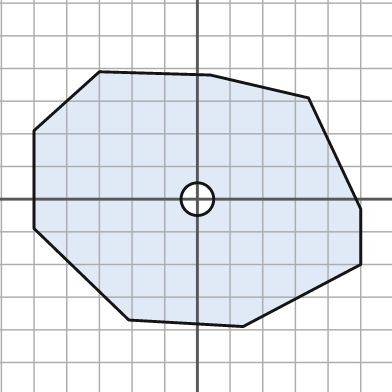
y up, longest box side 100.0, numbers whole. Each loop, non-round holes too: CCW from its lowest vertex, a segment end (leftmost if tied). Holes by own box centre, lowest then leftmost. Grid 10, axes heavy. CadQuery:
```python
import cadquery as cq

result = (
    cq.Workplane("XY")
    .moveTo(14.0, -39.0)
    .lineTo(50.0, -20.0)
    .lineTo(50.0, -3.0)
    .lineTo(34.0, 31.0)
    .lineTo(4.0, 38.0)
    .lineTo(-30.0, 39.0)
    .lineTo(-50.0, 21.0)
    .lineTo(-50.0, -9.0)
    .lineTo(-21.0, -37.0)
    .close()
    .moveTo(0.0, 0.0)
    .circle(5.0)
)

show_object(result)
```